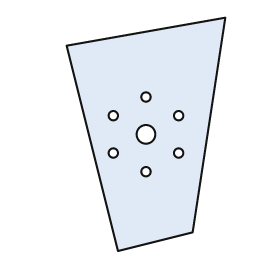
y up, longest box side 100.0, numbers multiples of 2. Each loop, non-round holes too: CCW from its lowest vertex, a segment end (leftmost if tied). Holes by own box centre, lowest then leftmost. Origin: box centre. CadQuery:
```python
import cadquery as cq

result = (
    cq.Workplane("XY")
    .moveTo(-12.0, -50.0)
    .lineTo(20.0, -42.0)
    .lineTo(34.0, 50.0)
    .lineTo(-34.0, 38.0)
    .close()
    .moveTo(0.0, -16.0)
    .circle(2.0)
    .moveTo(-14.0, -8.0)
    .circle(2.0)
    .moveTo(14.0, -8.0)
    .circle(2.0)
    .moveTo(0.0, 0.0)
    .circle(4.0)
    .moveTo(-14.0, 8.0)
    .circle(2.0)
    .moveTo(14.0, 8.0)
    .circle(2.0)
    .moveTo(0.0, 16.0)
    .circle(2.0)
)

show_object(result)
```